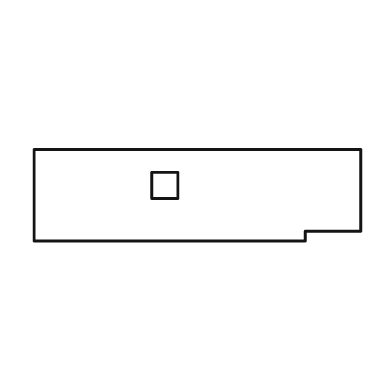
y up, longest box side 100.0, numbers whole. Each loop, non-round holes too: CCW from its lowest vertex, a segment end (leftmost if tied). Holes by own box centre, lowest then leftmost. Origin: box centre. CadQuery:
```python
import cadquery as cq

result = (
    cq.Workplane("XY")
    .moveTo(-50.0, -14.0)
    .lineTo(33.0, -14.0)
    .lineTo(33.0, -11.0)
    .lineTo(50.0, -11.0)
    .lineTo(50.0, 14.0)
    .lineTo(-50.0, 14.0)
    .close()
    .moveTo(-14.0, -1.0)
    .lineTo(-6.0, -1.0)
    .lineTo(-6.0, 7.0)
    .lineTo(-14.0, 7.0)
    .close()
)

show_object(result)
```